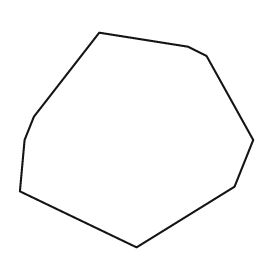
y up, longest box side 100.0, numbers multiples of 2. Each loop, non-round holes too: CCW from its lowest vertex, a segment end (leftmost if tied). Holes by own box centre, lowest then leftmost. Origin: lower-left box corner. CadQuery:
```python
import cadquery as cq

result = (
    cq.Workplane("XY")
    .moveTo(50.0, 0.0)
    .lineTo(92.0, 26.0)
    .lineTo(100.0, 46.0)
    .lineTo(80.0, 82.0)
    .lineTo(72.0, 86.0)
    .lineTo(34.0, 92.0)
    .lineTo(6.0, 56.0)
    .lineTo(2.0, 46.0)
    .lineTo(0.0, 24.0)
    .close()
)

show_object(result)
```